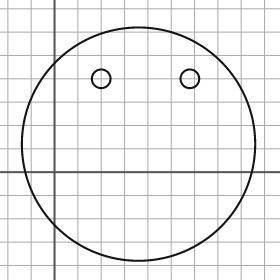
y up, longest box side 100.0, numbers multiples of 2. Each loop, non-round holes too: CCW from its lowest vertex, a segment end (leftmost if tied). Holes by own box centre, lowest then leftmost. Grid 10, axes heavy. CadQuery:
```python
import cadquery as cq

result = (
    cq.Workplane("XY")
    .moveTo(36.0, 12.0)
    .circle(50.0)
    .moveTo(20.0, 40.0)
    .circle(4.0)
    .moveTo(58.0, 40.0)
    .circle(4.0)
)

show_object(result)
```